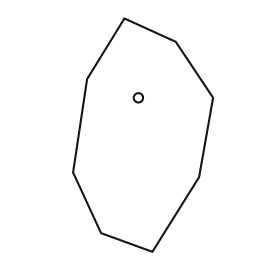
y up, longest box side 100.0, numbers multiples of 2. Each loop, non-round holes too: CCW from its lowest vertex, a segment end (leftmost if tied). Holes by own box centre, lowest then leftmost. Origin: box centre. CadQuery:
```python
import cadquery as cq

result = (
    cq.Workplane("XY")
    .moveTo(4.0, -50.0)
    .lineTo(24.0, -18.0)
    .lineTo(30.0, 16.0)
    .lineTo(14.0, 40.0)
    .lineTo(-8.0, 50.0)
    .lineTo(-24.0, 24.0)
    .lineTo(-30.0, -16.0)
    .lineTo(-18.0, -42.0)
    .close()
    .moveTo(-2.0, 16.0)
    .circle(2.0)
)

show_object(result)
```